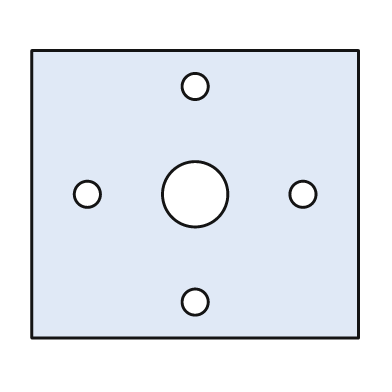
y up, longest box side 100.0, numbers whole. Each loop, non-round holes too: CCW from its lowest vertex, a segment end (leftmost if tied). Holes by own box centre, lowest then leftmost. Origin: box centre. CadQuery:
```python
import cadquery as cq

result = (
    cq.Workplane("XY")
    .moveTo(-50.0, -44.0)
    .lineTo(50.0, -44.0)
    .lineTo(50.0, 44.0)
    .lineTo(-50.0, 44.0)
    .close()
    .moveTo(0.0, -33.0)
    .circle(4.0)
    .moveTo(-33.0, 0.0)
    .circle(4.0)
    .moveTo(0.0, 0.0)
    .circle(10.0)
    .moveTo(33.0, 0.0)
    .circle(4.0)
    .moveTo(0.0, 33.0)
    .circle(4.0)
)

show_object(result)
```